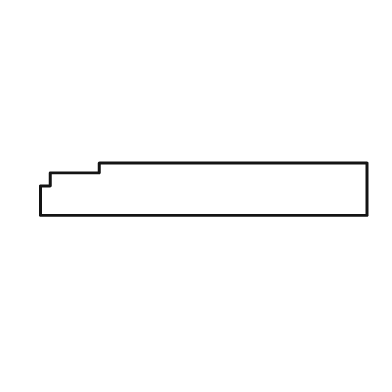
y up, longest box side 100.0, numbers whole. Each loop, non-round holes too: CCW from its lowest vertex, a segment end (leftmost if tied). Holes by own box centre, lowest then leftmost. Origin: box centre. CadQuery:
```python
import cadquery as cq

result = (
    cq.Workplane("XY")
    .moveTo(-50.0, -8.0)
    .lineTo(50.0, -8.0)
    .lineTo(50.0, 8.0)
    .lineTo(-32.0, 8.0)
    .lineTo(-32.0, 5.0)
    .lineTo(-47.0, 5.0)
    .lineTo(-47.0, 1.0)
    .lineTo(-50.0, 1.0)
    .close()
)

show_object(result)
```